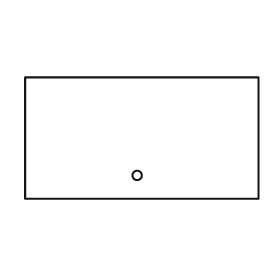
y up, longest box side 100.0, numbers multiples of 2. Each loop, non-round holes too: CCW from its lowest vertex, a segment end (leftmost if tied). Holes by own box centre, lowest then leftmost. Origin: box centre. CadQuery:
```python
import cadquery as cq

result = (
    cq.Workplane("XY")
    .moveTo(-50.0, -26.0)
    .lineTo(50.0, -26.0)
    .lineTo(50.0, 26.0)
    .lineTo(-50.0, 26.0)
    .close()
    .moveTo(-2.0, -16.0)
    .circle(2.0)
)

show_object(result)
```